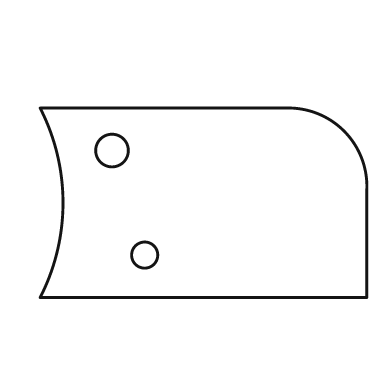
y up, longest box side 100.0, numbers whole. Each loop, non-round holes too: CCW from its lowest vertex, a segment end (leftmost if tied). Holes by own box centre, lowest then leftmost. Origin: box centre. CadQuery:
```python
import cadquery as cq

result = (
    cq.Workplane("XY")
    .moveTo(-50.0, -29.0)
    .lineTo(50.0, -29.0)
    .lineTo(50.0, 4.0)
    .threePointArc((43.0, 22.0), (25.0, 29.0))
    .lineTo(-50.0, 29.0)
    .threePointArc((-43.0, 0.0), (-50.0, -29.0))
    .close()
    .moveTo(-18.0, -16.0)
    .circle(4.0)
    .moveTo(-28.0, 16.0)
    .circle(5.0)
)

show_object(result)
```